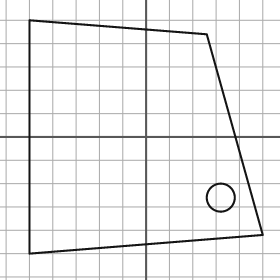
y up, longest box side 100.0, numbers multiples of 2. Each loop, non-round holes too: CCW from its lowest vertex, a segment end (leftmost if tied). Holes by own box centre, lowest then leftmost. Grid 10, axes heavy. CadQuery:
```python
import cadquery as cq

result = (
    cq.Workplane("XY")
    .moveTo(-50.0, -50.0)
    .lineTo(50.0, -42.0)
    .lineTo(26.0, 44.0)
    .lineTo(-50.0, 50.0)
    .close()
    .moveTo(32.0, -26.0)
    .circle(6.0)
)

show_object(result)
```